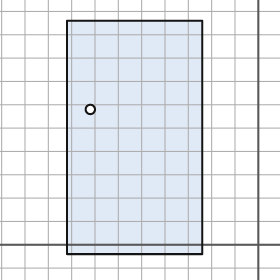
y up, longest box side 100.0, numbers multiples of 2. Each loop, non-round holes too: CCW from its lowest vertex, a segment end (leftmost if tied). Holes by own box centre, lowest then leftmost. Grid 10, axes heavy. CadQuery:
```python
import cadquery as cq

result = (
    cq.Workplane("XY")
    .moveTo(-82.0, -4.0)
    .lineTo(-24.0, -4.0)
    .lineTo(-24.0, 96.0)
    .lineTo(-82.0, 96.0)
    .close()
    .moveTo(-72.0, 58.0)
    .circle(2.0)
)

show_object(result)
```